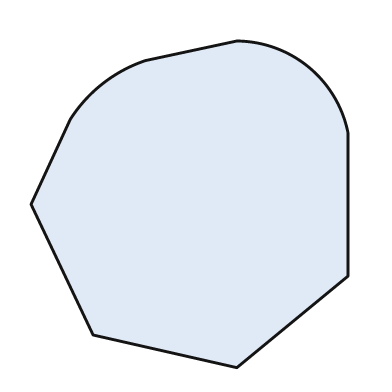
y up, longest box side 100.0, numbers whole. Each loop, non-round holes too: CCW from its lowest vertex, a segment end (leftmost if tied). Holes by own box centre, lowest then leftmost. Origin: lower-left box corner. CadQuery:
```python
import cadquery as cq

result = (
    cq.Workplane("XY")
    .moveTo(63.0, 0.0)
    .lineTo(97.0, 28.0)
    .lineTo(97.0, 72.0)
    .threePointArc((85.0, 92.0), (63.0, 100.0))
    .lineTo(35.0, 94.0)
    .threePointArc((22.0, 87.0), (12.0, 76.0))
    .lineTo(0.0, 50.0)
    .lineTo(19.0, 10.0)
    .close()
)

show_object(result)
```